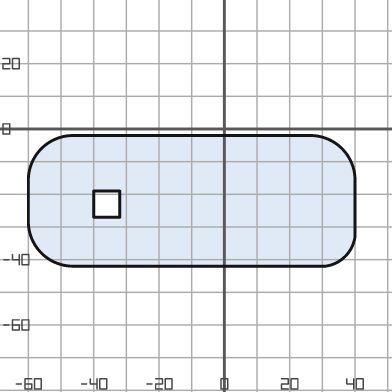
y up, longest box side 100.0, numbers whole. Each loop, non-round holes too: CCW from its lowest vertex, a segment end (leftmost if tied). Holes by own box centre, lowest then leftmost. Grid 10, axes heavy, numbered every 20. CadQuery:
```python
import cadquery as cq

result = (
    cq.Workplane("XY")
    .moveTo(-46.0, -42.0)
    .lineTo(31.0, -42.0)
    .threePointArc((37.0, -39.0), (40.0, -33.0))
    .lineTo(40.0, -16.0)
    .threePointArc((36.0, -6.0), (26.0, -2.0))
    .lineTo(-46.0, -2.0)
    .threePointArc((-56.0, -6.0), (-60.0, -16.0))
    .lineTo(-60.0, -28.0)
    .threePointArc((-56.0, -38.0), (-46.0, -42.0))
    .close()
    .moveTo(-40.0, -27.0)
    .lineTo(-32.0, -27.0)
    .lineTo(-32.0, -19.0)
    .lineTo(-40.0, -19.0)
    .close()
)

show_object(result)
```